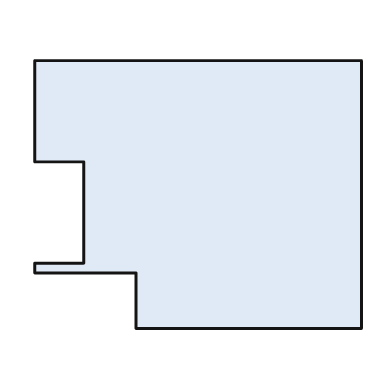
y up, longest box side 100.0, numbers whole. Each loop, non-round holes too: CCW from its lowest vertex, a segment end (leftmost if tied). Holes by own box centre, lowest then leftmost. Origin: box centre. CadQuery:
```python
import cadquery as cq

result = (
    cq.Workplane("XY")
    .moveTo(-19.0, -41.0)
    .lineTo(50.0, -41.0)
    .lineTo(50.0, 41.0)
    .lineTo(-50.0, 41.0)
    .lineTo(-50.0, 10.0)
    .lineTo(-35.0, 10.0)
    .lineTo(-35.0, -21.0)
    .lineTo(-50.0, -21.0)
    .lineTo(-50.0, -24.0)
    .lineTo(-19.0, -24.0)
    .close()
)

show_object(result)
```